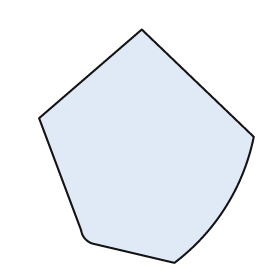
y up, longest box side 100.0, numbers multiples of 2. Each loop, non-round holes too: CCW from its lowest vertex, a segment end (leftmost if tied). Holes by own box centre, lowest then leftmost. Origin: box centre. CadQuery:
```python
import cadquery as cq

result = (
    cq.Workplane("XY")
    .moveTo(12.0, -50.0)
    .threePointArc((34.0, -26.0), (46.0, 4.0))
    .lineTo(-2.0, 50.0)
    .lineTo(-46.0, 12.0)
    .lineTo(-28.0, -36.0)
    .threePointArc((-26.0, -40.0), (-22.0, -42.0))
    .close()
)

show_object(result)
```